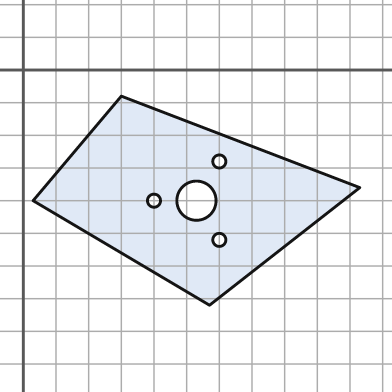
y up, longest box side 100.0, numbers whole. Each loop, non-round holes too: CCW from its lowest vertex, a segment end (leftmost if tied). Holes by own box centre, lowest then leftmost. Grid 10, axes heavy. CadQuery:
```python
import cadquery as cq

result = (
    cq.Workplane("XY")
    .moveTo(57.0, -72.0)
    .lineTo(103.0, -36.0)
    .lineTo(30.0, -8.0)
    .lineTo(3.0, -40.0)
    .close()
    .moveTo(60.0, -52.0)
    .circle(2.0)
    .moveTo(40.0, -40.0)
    .circle(2.0)
    .moveTo(53.0, -40.0)
    .circle(6.0)
    .moveTo(60.0, -28.0)
    .circle(2.0)
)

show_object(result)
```